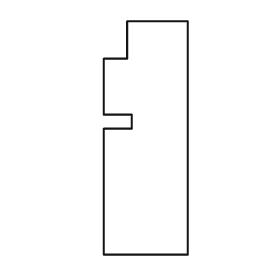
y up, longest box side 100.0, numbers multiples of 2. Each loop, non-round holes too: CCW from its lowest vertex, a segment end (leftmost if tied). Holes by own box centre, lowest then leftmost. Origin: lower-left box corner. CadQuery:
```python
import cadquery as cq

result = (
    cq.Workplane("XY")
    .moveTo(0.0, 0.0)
    .lineTo(36.0, 0.0)
    .lineTo(36.0, 100.0)
    .lineTo(10.0, 100.0)
    .lineTo(10.0, 84.0)
    .lineTo(0.0, 84.0)
    .lineTo(0.0, 60.0)
    .lineTo(12.0, 60.0)
    .lineTo(12.0, 54.0)
    .lineTo(0.0, 54.0)
    .close()
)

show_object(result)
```